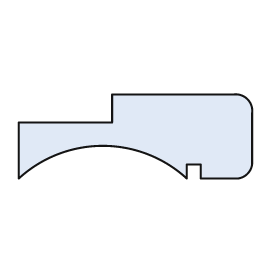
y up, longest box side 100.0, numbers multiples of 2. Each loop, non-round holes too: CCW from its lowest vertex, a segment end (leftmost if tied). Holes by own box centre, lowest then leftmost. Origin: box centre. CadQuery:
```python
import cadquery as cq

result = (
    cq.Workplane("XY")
    .moveTo(-50.0, -18.0)
    .threePointArc((-14.0, -4.0), (22.0, -18.0))
    .lineTo(22.0, -12.0)
    .lineTo(28.0, -12.0)
    .lineTo(28.0, -18.0)
    .lineTo(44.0, -18.0)
    .threePointArc((48.0, -16.0), (50.0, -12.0))
    .lineTo(50.0, 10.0)
    .threePointArc((48.0, 16.0), (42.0, 18.0))
    .lineTo(-10.0, 18.0)
    .lineTo(-10.0, 6.0)
    .lineTo(-50.0, 6.0)
    .close()
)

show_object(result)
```